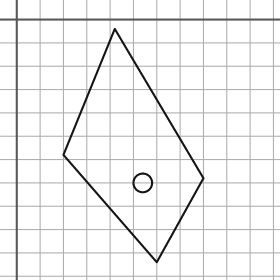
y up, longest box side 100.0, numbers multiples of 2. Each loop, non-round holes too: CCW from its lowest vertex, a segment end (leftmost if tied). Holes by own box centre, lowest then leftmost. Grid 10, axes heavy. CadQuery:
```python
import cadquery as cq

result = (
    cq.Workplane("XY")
    .moveTo(60.0, -104.0)
    .lineTo(80.0, -68.0)
    .lineTo(42.0, -4.0)
    .lineTo(20.0, -58.0)
    .close()
    .moveTo(54.0, -70.0)
    .circle(4.0)
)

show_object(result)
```